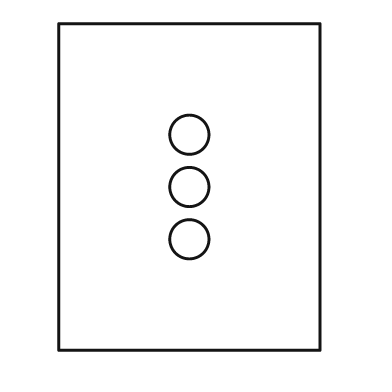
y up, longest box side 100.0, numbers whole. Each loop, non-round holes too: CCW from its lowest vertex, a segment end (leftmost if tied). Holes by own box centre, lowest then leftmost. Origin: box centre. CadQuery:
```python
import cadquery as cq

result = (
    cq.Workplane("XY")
    .moveTo(-40.0, -50.0)
    .lineTo(40.0, -50.0)
    .lineTo(40.0, 50.0)
    .lineTo(-40.0, 50.0)
    .close()
    .moveTo(0.0, -16.0)
    .circle(6.0)
    .moveTo(0.0, 0.0)
    .circle(6.0)
    .moveTo(0.0, 16.0)
    .circle(6.0)
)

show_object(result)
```